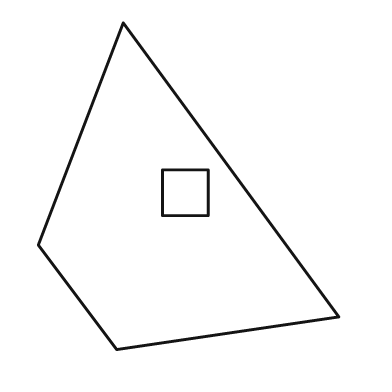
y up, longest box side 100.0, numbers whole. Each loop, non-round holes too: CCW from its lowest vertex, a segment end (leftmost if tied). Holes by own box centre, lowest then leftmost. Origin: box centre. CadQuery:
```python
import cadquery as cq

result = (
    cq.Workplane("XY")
    .moveTo(-22.0, -50.0)
    .lineTo(46.0, -40.0)
    .lineTo(-20.0, 50.0)
    .lineTo(-46.0, -18.0)
    .close()
    .moveTo(-8.0, -9.0)
    .lineTo(6.0, -9.0)
    .lineTo(6.0, 5.0)
    .lineTo(-8.0, 5.0)
    .close()
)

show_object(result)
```